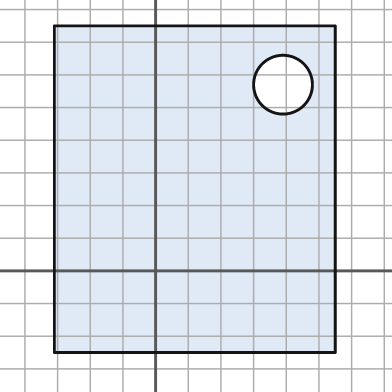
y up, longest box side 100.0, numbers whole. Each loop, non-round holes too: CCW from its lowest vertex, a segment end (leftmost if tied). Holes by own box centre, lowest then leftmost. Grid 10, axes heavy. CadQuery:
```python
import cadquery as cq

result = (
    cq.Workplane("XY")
    .moveTo(-31.0, -25.0)
    .lineTo(55.0, -25.0)
    .lineTo(55.0, 75.0)
    .lineTo(-31.0, 75.0)
    .close()
    .moveTo(39.0, 57.0)
    .circle(9.0)
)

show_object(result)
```